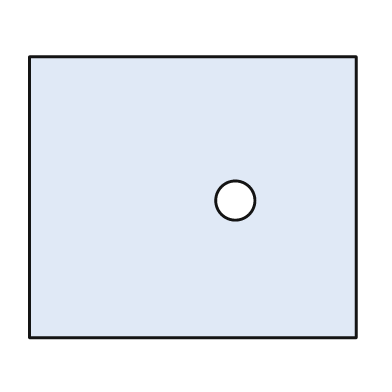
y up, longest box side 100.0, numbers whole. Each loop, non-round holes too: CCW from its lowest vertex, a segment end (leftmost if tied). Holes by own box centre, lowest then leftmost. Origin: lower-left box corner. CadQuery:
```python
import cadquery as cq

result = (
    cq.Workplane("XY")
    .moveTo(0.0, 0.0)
    .lineTo(100.0, 0.0)
    .lineTo(100.0, 86.0)
    .lineTo(0.0, 86.0)
    .close()
    .moveTo(63.0, 42.0)
    .circle(6.0)
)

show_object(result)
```